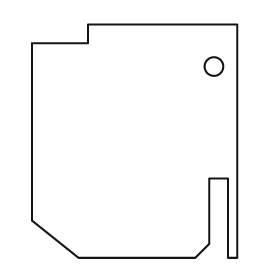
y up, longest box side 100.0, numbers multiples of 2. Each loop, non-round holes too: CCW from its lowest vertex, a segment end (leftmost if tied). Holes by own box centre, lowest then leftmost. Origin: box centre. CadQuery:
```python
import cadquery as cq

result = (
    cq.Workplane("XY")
    .moveTo(-24.0, -50.0)
    .lineTo(26.0, -50.0)
    .lineTo(32.0, -44.0)
    .lineTo(32.0, -16.0)
    .lineTo(40.0, -16.0)
    .lineTo(40.0, -50.0)
    .lineTo(44.0, -50.0)
    .lineTo(44.0, 50.0)
    .lineTo(-20.0, 50.0)
    .lineTo(-20.0, 42.0)
    .lineTo(-44.0, 42.0)
    .lineTo(-44.0, -34.0)
    .close()
    .moveTo(34.0, 32.0)
    .circle(4.0)
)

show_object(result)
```